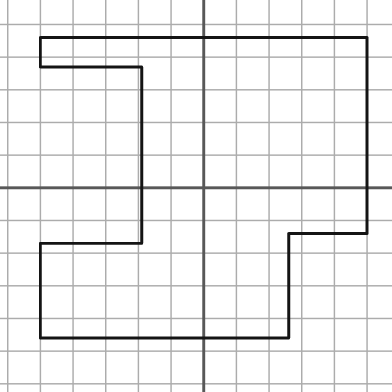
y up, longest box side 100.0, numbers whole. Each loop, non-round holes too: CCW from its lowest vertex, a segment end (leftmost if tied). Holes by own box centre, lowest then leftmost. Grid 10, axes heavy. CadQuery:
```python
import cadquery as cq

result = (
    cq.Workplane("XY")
    .moveTo(-50.0, -46.0)
    .lineTo(26.0, -46.0)
    .lineTo(26.0, -14.0)
    .lineTo(50.0, -14.0)
    .lineTo(50.0, 46.0)
    .lineTo(-50.0, 46.0)
    .lineTo(-50.0, 37.0)
    .lineTo(-19.0, 37.0)
    .lineTo(-19.0, -17.0)
    .lineTo(-50.0, -17.0)
    .close()
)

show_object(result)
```